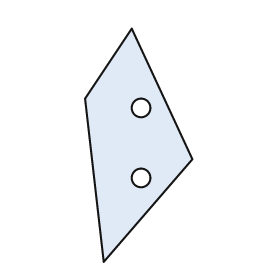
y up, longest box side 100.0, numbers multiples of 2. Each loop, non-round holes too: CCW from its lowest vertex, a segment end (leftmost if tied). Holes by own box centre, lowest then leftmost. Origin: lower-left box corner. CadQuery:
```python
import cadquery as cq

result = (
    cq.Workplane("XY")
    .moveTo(8.0, 0.0)
    .lineTo(46.0, 44.0)
    .lineTo(20.0, 100.0)
    .lineTo(0.0, 70.0)
    .close()
    .moveTo(24.0, 36.0)
    .circle(4.0)
    .moveTo(24.0, 66.0)
    .circle(4.0)
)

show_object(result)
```